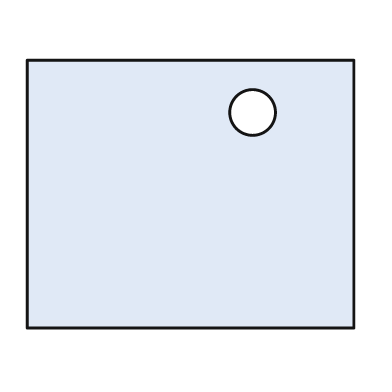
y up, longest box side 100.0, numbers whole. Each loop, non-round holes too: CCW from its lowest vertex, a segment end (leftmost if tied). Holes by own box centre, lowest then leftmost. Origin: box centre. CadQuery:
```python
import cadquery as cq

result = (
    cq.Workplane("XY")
    .moveTo(-50.0, -41.0)
    .lineTo(50.0, -41.0)
    .lineTo(50.0, 41.0)
    .lineTo(-50.0, 41.0)
    .close()
    .moveTo(19.0, 25.0)
    .circle(7.0)
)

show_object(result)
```